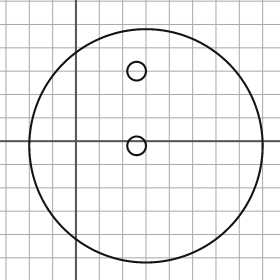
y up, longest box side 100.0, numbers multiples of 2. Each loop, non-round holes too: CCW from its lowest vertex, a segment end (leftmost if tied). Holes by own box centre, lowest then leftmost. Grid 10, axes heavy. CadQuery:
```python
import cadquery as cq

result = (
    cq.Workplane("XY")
    .moveTo(30.0, -2.0)
    .circle(50.0)
    .moveTo(26.0, -2.0)
    .circle(4.0)
    .moveTo(26.0, 30.0)
    .circle(4.0)
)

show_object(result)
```